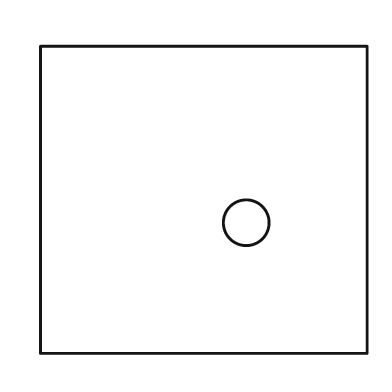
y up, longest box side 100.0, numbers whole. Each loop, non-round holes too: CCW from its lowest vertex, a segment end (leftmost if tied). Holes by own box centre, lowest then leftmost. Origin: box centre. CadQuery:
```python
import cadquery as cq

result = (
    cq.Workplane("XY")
    .moveTo(-50.0, -47.0)
    .lineTo(50.0, -47.0)
    .lineTo(50.0, 47.0)
    .lineTo(-50.0, 47.0)
    .close()
    .moveTo(13.0, -7.0)
    .circle(7.0)
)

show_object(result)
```